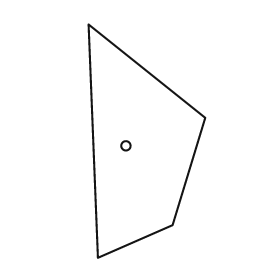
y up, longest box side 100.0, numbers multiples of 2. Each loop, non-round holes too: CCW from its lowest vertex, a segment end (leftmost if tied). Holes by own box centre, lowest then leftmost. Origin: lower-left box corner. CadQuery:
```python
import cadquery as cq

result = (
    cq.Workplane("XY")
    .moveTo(4.0, 0.0)
    .lineTo(36.0, 14.0)
    .lineTo(50.0, 60.0)
    .lineTo(0.0, 100.0)
    .close()
    .moveTo(16.0, 48.0)
    .circle(2.0)
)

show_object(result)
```